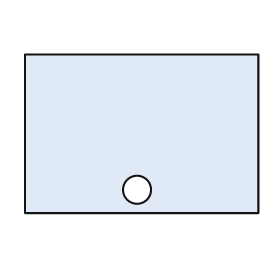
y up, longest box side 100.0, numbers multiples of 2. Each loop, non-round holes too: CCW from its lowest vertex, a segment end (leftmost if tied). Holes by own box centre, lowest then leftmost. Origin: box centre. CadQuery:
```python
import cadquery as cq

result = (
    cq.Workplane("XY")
    .moveTo(-50.0, -34.0)
    .lineTo(50.0, -34.0)
    .lineTo(50.0, 34.0)
    .lineTo(-50.0, 34.0)
    .close()
    .moveTo(-2.0, -24.0)
    .circle(6.0)
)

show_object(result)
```